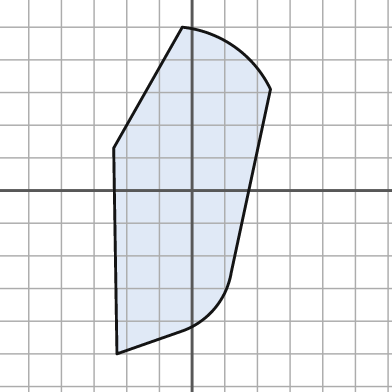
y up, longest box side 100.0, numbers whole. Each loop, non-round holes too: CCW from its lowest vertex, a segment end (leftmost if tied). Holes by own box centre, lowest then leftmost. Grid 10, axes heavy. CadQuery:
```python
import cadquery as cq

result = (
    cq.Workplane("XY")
    .moveTo(-23.0, -50.0)
    .lineTo(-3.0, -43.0)
    .threePointArc((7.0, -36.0), (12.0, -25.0))
    .lineTo(24.0, 31.0)
    .threePointArc((13.0, 44.0), (-3.0, 50.0))
    .lineTo(-24.0, 13.0)
    .close()
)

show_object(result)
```